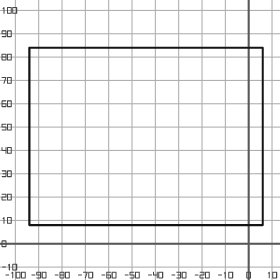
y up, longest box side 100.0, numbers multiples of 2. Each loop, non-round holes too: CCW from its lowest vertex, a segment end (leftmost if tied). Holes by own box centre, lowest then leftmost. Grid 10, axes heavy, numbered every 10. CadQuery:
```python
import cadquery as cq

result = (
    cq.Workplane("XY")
    .moveTo(-94.0, 8.0)
    .lineTo(6.0, 8.0)
    .lineTo(6.0, 84.0)
    .lineTo(-94.0, 84.0)
    .close()
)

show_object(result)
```